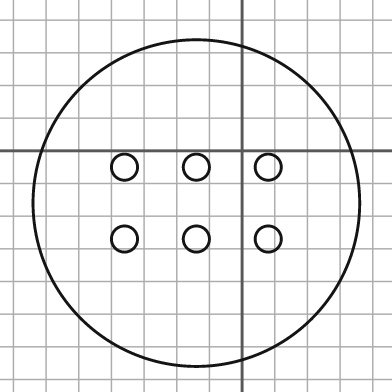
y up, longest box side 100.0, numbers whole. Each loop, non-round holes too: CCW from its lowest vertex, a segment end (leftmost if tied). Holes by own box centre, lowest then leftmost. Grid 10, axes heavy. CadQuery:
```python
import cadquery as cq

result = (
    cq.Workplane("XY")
    .moveTo(-14.0, -16.0)
    .circle(50.0)
    .moveTo(-36.0, -27.0)
    .circle(4.0)
    .moveTo(-14.0, -27.0)
    .circle(4.0)
    .moveTo(8.0, -27.0)
    .circle(4.0)
    .moveTo(-36.0, -5.0)
    .circle(4.0)
    .moveTo(-14.0, -5.0)
    .circle(4.0)
    .moveTo(8.0, -5.0)
    .circle(4.0)
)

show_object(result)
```